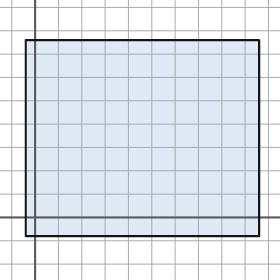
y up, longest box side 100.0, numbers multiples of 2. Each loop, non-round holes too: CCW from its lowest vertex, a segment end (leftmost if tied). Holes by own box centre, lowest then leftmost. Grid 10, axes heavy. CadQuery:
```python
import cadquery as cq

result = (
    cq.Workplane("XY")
    .moveTo(-4.0, -8.0)
    .lineTo(96.0, -8.0)
    .lineTo(96.0, 76.0)
    .lineTo(-4.0, 76.0)
    .close()
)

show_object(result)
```